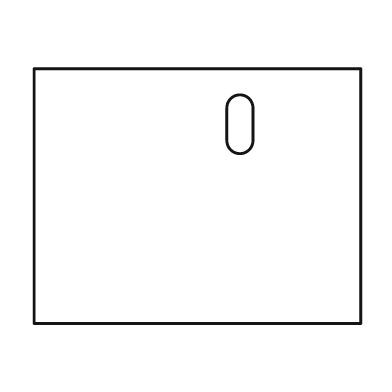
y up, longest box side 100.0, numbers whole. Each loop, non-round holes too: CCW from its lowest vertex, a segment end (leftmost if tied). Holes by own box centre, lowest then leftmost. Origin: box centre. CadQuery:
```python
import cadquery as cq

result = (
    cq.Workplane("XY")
    .moveTo(-50.0, -39.0)
    .lineTo(50.0, -39.0)
    .lineTo(50.0, 39.0)
    .lineTo(-50.0, 39.0)
    .close()
    .moveTo(9.0, 17.0)
    .threePointArc((13.0, 13.0), (17.0, 17.0))
    .lineTo(17.0, 27.0)
    .threePointArc((13.0, 31.0), (9.0, 27.0))
    .close()
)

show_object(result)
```